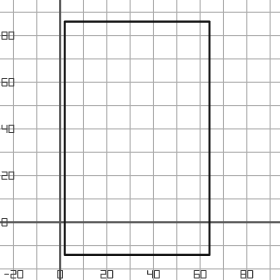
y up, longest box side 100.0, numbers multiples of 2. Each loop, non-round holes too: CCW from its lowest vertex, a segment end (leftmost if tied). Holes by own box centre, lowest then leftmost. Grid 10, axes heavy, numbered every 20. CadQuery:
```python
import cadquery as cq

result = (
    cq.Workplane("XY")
    .moveTo(2.0, -14.0)
    .lineTo(64.0, -14.0)
    .lineTo(64.0, 86.0)
    .lineTo(2.0, 86.0)
    .close()
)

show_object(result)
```